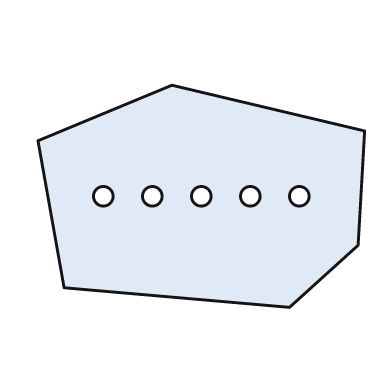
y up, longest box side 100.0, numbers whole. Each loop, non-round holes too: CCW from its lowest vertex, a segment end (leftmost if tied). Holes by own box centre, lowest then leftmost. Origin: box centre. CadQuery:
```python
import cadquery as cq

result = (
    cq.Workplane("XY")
    .moveTo(27.0, -34.0)
    .lineTo(48.0, -15.0)
    .lineTo(50.0, 20.0)
    .lineTo(-9.0, 34.0)
    .lineTo(-50.0, 17.0)
    .lineTo(-42.0, -28.0)
    .close()
    .moveTo(-30.0, 0.0)
    .circle(3.0)
    .moveTo(-15.0, 0.0)
    .circle(3.0)
    .moveTo(0.0, 0.0)
    .circle(3.0)
    .moveTo(15.0, 0.0)
    .circle(3.0)
    .moveTo(30.0, 0.0)
    .circle(3.0)
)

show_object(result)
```